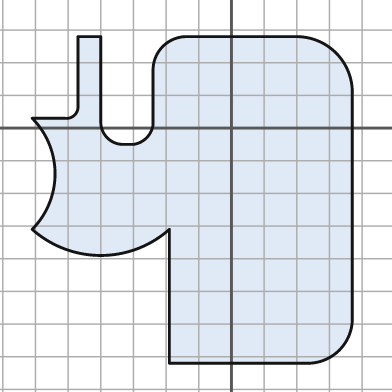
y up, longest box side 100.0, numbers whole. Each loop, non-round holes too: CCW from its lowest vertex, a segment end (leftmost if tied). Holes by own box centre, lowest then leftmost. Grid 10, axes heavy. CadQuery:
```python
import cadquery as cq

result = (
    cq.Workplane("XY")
    .moveTo(-19.0, -72.0)
    .lineTo(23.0, -72.0)
    .threePointArc((33.0, -68.0), (37.0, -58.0))
    .lineTo(37.0, 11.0)
    .threePointArc((32.0, 23.0), (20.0, 28.0))
    .lineTo(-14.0, 28.0)
    .threePointArc((-21.0, 25.0), (-24.0, 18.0))
    .lineTo(-24.0, 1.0)
    .threePointArc((-26.0, -3.0), (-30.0, -5.0))
    .lineTo(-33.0, -5.0)
    .threePointArc((-38.0, -3.0), (-40.0, 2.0))
    .lineTo(-40.0, 28.0)
    .lineTo(-47.0, 28.0)
    .lineTo(-47.0, 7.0)
    .threePointArc((-48.0, 4.0), (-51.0, 3.0))
    .lineTo(-61.0, 3.0)
    .threePointArc((-54.0, -14.0), (-61.0, -31.0))
    .threePointArc((-40.0, -39.0), (-19.0, -31.0))
    .close()
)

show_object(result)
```